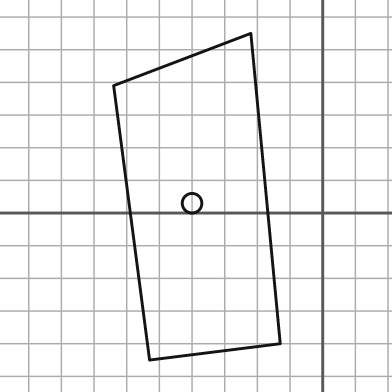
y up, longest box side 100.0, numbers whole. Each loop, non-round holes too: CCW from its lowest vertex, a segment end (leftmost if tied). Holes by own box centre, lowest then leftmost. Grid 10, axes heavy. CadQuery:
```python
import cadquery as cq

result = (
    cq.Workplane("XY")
    .moveTo(-53.0, -45.0)
    .lineTo(-13.0, -40.0)
    .lineTo(-22.0, 55.0)
    .lineTo(-64.0, 39.0)
    .close()
    .moveTo(-40.0, 3.0)
    .circle(3.0)
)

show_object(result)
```